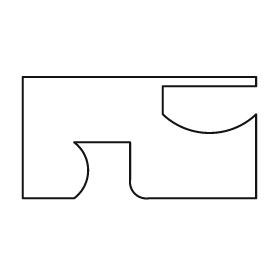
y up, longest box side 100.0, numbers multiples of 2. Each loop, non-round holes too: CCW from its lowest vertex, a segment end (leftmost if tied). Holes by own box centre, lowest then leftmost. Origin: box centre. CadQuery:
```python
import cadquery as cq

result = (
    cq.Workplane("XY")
    .moveTo(-50.0, -26.0)
    .lineTo(-28.0, -26.0)
    .threePointArc((-22.0, -14.0), (-28.0, -2.0))
    .lineTo(-4.0, -2.0)
    .lineTo(-4.0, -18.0)
    .threePointArc((-2.0, -24.0), (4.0, -26.0))
    .lineTo(50.0, -26.0)
    .lineTo(50.0, 10.0)
    .threePointArc((30.0, 2.0), (10.0, 10.0))
    .lineTo(10.0, 22.0)
    .lineTo(50.0, 22.0)
    .lineTo(50.0, 26.0)
    .lineTo(-50.0, 26.0)
    .close()
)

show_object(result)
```